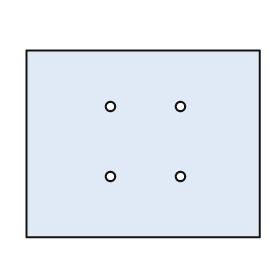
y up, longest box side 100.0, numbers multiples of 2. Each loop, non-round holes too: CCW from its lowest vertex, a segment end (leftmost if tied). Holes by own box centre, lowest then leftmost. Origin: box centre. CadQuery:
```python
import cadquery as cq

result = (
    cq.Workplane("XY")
    .moveTo(-50.0, -40.0)
    .lineTo(50.0, -40.0)
    .lineTo(50.0, 40.0)
    .lineTo(-50.0, 40.0)
    .close()
    .moveTo(-14.0, -14.0)
    .circle(2.0)
    .moveTo(16.0, -14.0)
    .circle(2.0)
    .moveTo(-14.0, 16.0)
    .circle(2.0)
    .moveTo(16.0, 16.0)
    .circle(2.0)
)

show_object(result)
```